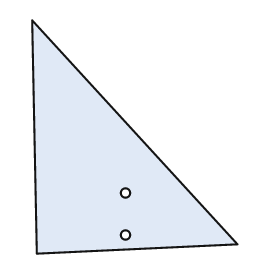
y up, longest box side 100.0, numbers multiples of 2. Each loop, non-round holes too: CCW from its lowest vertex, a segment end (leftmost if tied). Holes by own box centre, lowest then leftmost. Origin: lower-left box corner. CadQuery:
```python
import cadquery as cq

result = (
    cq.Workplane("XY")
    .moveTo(2.0, 0.0)
    .lineTo(88.0, 4.0)
    .lineTo(0.0, 100.0)
    .close()
    .moveTo(40.0, 8.0)
    .circle(2.0)
    .moveTo(40.0, 26.0)
    .circle(2.0)
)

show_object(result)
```